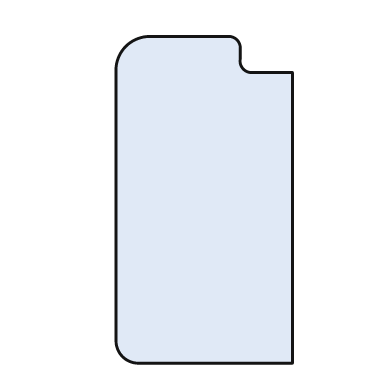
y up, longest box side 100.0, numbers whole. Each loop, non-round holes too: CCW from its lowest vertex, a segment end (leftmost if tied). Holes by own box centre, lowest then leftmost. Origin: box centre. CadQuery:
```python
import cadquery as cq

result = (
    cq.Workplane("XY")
    .moveTo(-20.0, -50.0)
    .lineTo(27.0, -50.0)
    .lineTo(27.0, 39.0)
    .lineTo(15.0, 39.0)
    .threePointArc((12.0, 40.0), (11.0, 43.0))
    .lineTo(11.0, 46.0)
    .threePointArc((10.0, 49.0), (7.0, 50.0))
    .lineTo(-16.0, 50.0)
    .threePointArc((-24.0, 47.0), (-27.0, 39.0))
    .lineTo(-27.0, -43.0)
    .threePointArc((-25.0, -48.0), (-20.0, -50.0))
    .close()
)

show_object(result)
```